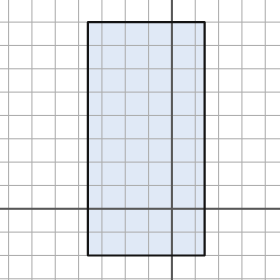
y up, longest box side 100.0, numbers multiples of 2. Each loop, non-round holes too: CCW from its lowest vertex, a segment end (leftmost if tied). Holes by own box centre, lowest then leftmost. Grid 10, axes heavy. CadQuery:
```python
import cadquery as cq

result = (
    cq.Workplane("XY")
    .moveTo(-36.0, -20.0)
    .lineTo(14.0, -20.0)
    .lineTo(14.0, 80.0)
    .lineTo(-36.0, 80.0)
    .close()
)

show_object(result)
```